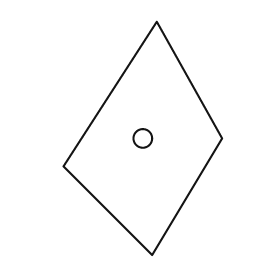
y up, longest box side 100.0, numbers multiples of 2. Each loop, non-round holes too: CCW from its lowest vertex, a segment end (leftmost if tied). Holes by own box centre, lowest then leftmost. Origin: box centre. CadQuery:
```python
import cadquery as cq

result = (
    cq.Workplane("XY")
    .moveTo(4.0, -50.0)
    .lineTo(34.0, 0.0)
    .lineTo(6.0, 50.0)
    .lineTo(-34.0, -12.0)
    .close()
    .moveTo(0.0, 0.0)
    .circle(4.0)
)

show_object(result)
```